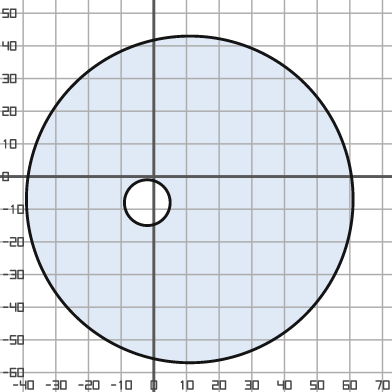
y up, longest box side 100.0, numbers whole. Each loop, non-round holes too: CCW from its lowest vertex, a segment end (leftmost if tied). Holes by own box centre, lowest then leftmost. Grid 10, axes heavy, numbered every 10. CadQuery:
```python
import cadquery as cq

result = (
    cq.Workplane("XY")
    .moveTo(11.0, -7.0)
    .circle(50.0)
    .moveTo(-2.0, -8.0)
    .circle(7.0)
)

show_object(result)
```